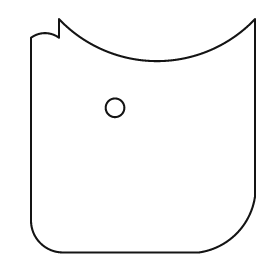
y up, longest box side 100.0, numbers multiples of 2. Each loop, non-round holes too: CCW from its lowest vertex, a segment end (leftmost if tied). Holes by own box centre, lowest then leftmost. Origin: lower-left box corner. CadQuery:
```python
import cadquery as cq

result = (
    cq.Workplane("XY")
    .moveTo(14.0, 0.0)
    .lineTo(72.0, 0.0)
    .threePointArc((88.0, 8.0), (96.0, 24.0))
    .lineTo(96.0, 100.0)
    .threePointArc((54.0, 82.0), (12.0, 100.0))
    .lineTo(12.0, 92.0)
    .threePointArc((6.0, 94.0), (0.0, 92.0))
    .lineTo(0.0, 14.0)
    .threePointArc((4.0, 4.0), (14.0, 0.0))
    .close()
    .moveTo(36.0, 62.0)
    .circle(4.0)
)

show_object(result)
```